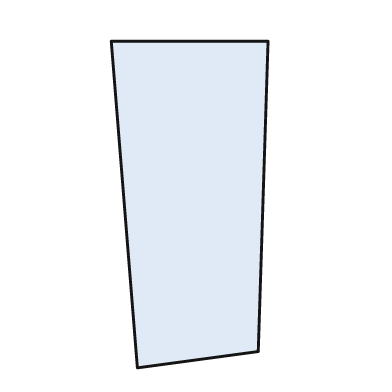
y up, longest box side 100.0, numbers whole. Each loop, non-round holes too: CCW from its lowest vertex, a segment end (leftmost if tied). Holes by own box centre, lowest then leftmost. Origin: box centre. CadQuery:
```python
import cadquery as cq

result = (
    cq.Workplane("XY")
    .moveTo(-16.0, -50.0)
    .lineTo(21.0, -45.0)
    .lineTo(24.0, 50.0)
    .lineTo(-24.0, 50.0)
    .close()
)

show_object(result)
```